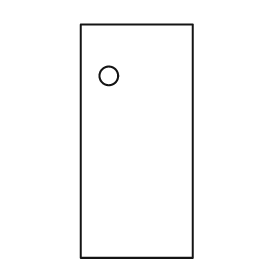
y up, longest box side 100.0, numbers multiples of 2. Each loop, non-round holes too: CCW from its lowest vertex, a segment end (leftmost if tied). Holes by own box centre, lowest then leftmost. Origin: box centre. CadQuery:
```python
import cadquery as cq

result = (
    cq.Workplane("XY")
    .moveTo(-24.0, -50.0)
    .lineTo(24.0, -50.0)
    .lineTo(24.0, 50.0)
    .lineTo(-24.0, 50.0)
    .close()
    .moveTo(-12.0, 28.0)
    .circle(4.0)
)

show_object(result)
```